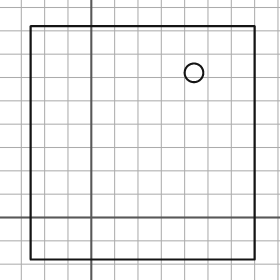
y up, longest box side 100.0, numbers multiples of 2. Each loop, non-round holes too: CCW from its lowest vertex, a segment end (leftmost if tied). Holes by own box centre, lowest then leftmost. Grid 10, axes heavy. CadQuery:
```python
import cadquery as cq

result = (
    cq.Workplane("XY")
    .moveTo(-26.0, -18.0)
    .lineTo(70.0, -18.0)
    .lineTo(70.0, 82.0)
    .lineTo(-26.0, 82.0)
    .close()
    .moveTo(44.0, 62.0)
    .circle(4.0)
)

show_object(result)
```